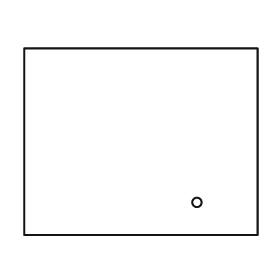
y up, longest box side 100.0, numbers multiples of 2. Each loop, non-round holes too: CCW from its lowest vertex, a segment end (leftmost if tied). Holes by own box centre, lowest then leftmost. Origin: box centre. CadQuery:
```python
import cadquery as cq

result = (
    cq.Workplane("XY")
    .moveTo(-50.0, -40.0)
    .lineTo(50.0, -40.0)
    .lineTo(50.0, 40.0)
    .lineTo(-50.0, 40.0)
    .close()
    .moveTo(24.0, -26.0)
    .circle(2.0)
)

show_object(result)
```